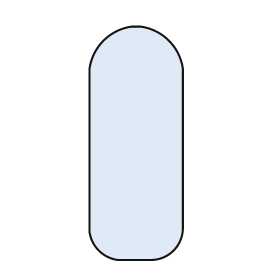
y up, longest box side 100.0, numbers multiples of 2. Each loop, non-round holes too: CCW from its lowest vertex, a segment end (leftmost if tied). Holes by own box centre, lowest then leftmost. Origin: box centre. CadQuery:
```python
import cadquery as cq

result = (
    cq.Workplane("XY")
    .moveTo(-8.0, -50.0)
    .lineTo(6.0, -50.0)
    .threePointArc((16.0, -46.0), (20.0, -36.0))
    .lineTo(20.0, 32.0)
    .threePointArc((14.0, 44.0), (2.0, 50.0))
    .lineTo(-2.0, 50.0)
    .threePointArc((-14.0, 44.0), (-20.0, 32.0))
    .lineTo(-20.0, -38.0)
    .threePointArc((-16.0, -46.0), (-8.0, -50.0))
    .close()
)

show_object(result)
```